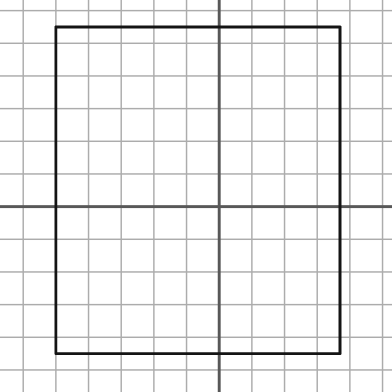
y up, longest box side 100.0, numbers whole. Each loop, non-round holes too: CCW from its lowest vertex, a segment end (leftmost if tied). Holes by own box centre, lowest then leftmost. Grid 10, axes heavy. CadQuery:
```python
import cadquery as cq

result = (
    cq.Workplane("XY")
    .moveTo(-50.0, -45.0)
    .lineTo(37.0, -45.0)
    .lineTo(37.0, 55.0)
    .lineTo(-50.0, 55.0)
    .close()
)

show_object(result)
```